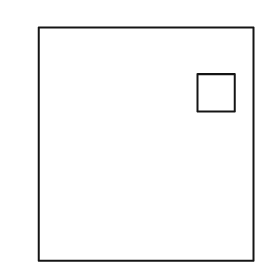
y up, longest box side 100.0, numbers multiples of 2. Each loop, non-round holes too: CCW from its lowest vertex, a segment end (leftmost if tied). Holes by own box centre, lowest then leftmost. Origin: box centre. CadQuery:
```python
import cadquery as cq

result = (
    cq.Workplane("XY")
    .moveTo(-46.0, -50.0)
    .lineTo(46.0, -50.0)
    .lineTo(46.0, 50.0)
    .lineTo(-46.0, 50.0)
    .close()
    .moveTo(22.0, 14.0)
    .lineTo(38.0, 14.0)
    .lineTo(38.0, 30.0)
    .lineTo(22.0, 30.0)
    .close()
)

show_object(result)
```